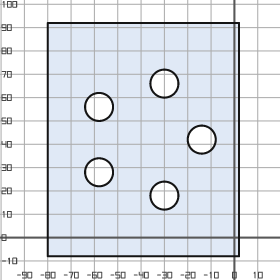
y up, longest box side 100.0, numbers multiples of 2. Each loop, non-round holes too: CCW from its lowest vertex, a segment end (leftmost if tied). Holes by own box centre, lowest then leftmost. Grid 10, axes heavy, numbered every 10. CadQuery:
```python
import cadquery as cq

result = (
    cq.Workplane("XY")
    .moveTo(-80.0, -8.0)
    .lineTo(2.0, -8.0)
    .lineTo(2.0, 92.0)
    .lineTo(-80.0, 92.0)
    .close()
    .moveTo(-30.0, 18.0)
    .circle(6.0)
    .moveTo(-58.0, 28.0)
    .circle(6.0)
    .moveTo(-14.0, 42.0)
    .circle(6.0)
    .moveTo(-58.0, 56.0)
    .circle(6.0)
    .moveTo(-30.0, 66.0)
    .circle(6.0)
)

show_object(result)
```